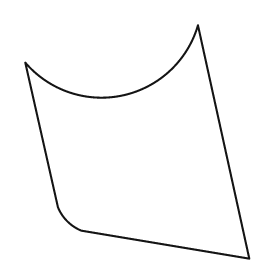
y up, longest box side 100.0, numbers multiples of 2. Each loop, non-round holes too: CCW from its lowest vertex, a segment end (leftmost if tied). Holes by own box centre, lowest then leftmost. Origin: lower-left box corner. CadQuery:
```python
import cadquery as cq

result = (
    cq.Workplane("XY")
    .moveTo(96.0, 0.0)
    .lineTo(74.0, 100.0)
    .threePointArc((42.0, 70.0), (0.0, 84.0))
    .lineTo(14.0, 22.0)
    .threePointArc((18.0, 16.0), (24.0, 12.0))
    .close()
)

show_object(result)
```